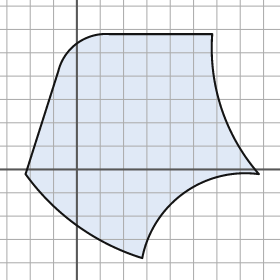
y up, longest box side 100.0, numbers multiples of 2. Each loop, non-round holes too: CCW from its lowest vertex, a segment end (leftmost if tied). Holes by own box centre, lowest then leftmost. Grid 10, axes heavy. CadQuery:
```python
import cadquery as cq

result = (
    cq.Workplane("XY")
    .moveTo(28.0, -38.0)
    .threePointArc((46.0, -10.0), (78.0, -2.0))
    .threePointArc((62.0, 26.0), (58.0, 58.0))
    .lineTo(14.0, 58.0)
    .threePointArc((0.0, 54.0), (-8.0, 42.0))
    .lineTo(-22.0, -2.0)
    .threePointArc((0.0, -24.0), (28.0, -38.0))
    .close()
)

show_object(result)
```